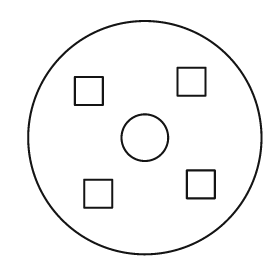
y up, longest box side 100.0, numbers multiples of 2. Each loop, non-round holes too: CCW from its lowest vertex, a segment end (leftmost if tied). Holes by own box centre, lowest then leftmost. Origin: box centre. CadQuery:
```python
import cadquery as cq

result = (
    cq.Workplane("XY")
    .moveTo(0.0, 0.0)
    .circle(50.0)
    .moveTo(-26.0, -30.0)
    .lineTo(-14.0, -30.0)
    .lineTo(-14.0, -18.0)
    .lineTo(-26.0, -18.0)
    .close()
    .moveTo(18.0, -26.0)
    .lineTo(30.0, -26.0)
    .lineTo(30.0, -14.0)
    .lineTo(18.0, -14.0)
    .close()
    .moveTo(0.0, 0.0)
    .circle(10.0)
    .moveTo(-30.0, 14.0)
    .lineTo(-18.0, 14.0)
    .lineTo(-18.0, 26.0)
    .lineTo(-30.0, 26.0)
    .close()
    .moveTo(14.0, 18.0)
    .lineTo(26.0, 18.0)
    .lineTo(26.0, 30.0)
    .lineTo(14.0, 30.0)
    .close()
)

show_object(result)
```